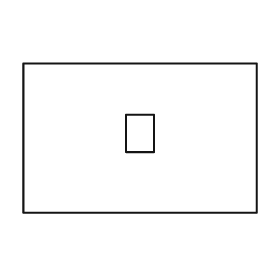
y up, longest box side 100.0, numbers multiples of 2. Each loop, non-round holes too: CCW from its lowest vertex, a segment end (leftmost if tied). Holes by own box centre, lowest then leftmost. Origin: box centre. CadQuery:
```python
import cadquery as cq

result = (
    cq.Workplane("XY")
    .moveTo(-50.0, -32.0)
    .lineTo(50.0, -32.0)
    .lineTo(50.0, 32.0)
    .lineTo(-50.0, 32.0)
    .close()
    .moveTo(-6.0, -6.0)
    .lineTo(6.0, -6.0)
    .lineTo(6.0, 10.0)
    .lineTo(-6.0, 10.0)
    .close()
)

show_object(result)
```